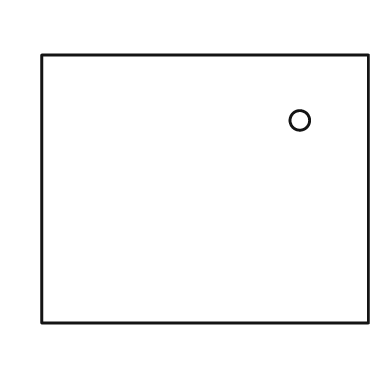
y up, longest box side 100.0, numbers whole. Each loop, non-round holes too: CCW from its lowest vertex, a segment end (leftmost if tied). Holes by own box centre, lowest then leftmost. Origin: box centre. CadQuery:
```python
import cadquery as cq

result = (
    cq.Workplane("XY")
    .moveTo(-50.0, -41.0)
    .lineTo(50.0, -41.0)
    .lineTo(50.0, 41.0)
    .lineTo(-50.0, 41.0)
    .close()
    .moveTo(29.0, 21.0)
    .circle(3.0)
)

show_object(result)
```